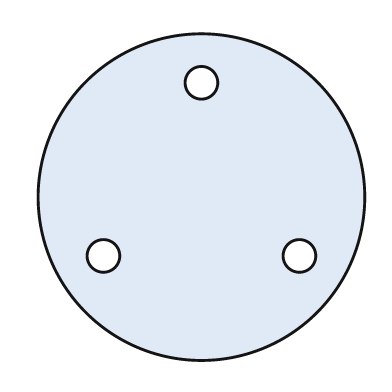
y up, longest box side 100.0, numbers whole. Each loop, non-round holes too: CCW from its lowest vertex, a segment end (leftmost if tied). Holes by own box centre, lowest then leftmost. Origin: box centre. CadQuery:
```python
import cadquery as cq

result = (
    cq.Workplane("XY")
    .moveTo(0.0, 0.0)
    .circle(50.0)
    .moveTo(-30.0, -18.0)
    .circle(5.0)
    .moveTo(30.0, -18.0)
    .circle(5.0)
    .moveTo(0.0, 35.0)
    .circle(5.0)
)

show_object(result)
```